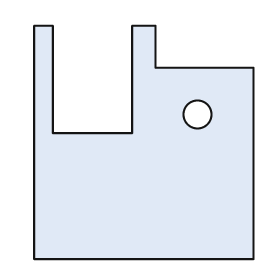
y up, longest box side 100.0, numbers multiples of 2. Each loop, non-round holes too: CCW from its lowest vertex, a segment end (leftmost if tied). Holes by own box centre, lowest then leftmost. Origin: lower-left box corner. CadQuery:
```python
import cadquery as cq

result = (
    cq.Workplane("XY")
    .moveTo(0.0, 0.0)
    .lineTo(94.0, 0.0)
    .lineTo(94.0, 82.0)
    .lineTo(52.0, 82.0)
    .lineTo(52.0, 100.0)
    .lineTo(42.0, 100.0)
    .lineTo(42.0, 54.0)
    .lineTo(8.0, 54.0)
    .lineTo(8.0, 100.0)
    .lineTo(0.0, 100.0)
    .close()
    .moveTo(70.0, 62.0)
    .circle(6.0)
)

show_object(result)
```